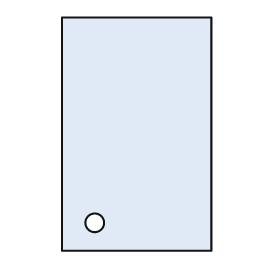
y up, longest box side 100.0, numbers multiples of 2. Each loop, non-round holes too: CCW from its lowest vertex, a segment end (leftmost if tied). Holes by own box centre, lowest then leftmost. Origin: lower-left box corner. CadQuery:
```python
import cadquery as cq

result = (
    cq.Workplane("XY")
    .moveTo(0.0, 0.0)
    .lineTo(64.0, 0.0)
    .lineTo(64.0, 100.0)
    .lineTo(0.0, 100.0)
    .close()
    .moveTo(14.0, 12.0)
    .circle(4.0)
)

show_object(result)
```